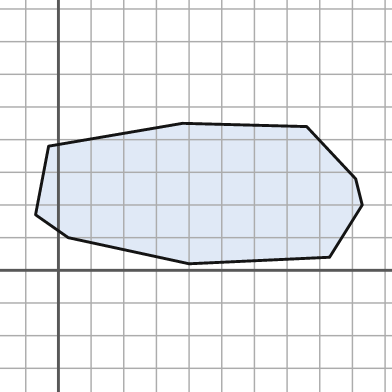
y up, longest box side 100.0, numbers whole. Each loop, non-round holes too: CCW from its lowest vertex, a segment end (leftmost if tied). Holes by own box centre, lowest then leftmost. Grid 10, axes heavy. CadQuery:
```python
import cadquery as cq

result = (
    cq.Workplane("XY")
    .moveTo(40.0, 2.0)
    .lineTo(83.0, 4.0)
    .lineTo(93.0, 20.0)
    .lineTo(91.0, 28.0)
    .lineTo(76.0, 44.0)
    .lineTo(38.0, 45.0)
    .lineTo(-3.0, 38.0)
    .lineTo(-7.0, 17.0)
    .lineTo(3.0, 10.0)
    .close()
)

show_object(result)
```